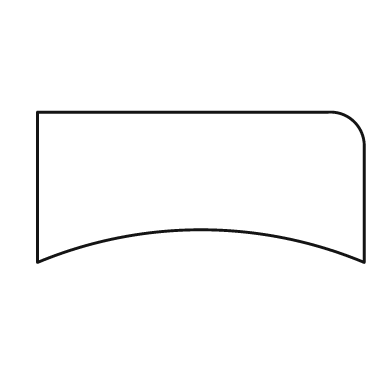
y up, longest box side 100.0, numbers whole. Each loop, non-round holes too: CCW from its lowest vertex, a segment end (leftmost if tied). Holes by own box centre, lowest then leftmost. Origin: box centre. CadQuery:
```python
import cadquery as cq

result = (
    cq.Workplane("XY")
    .moveTo(-50.0, -23.0)
    .threePointArc((0.0, -13.0), (50.0, -23.0))
    .lineTo(50.0, 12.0)
    .threePointArc((47.0, 20.0), (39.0, 23.0))
    .lineTo(-50.0, 23.0)
    .close()
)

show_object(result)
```